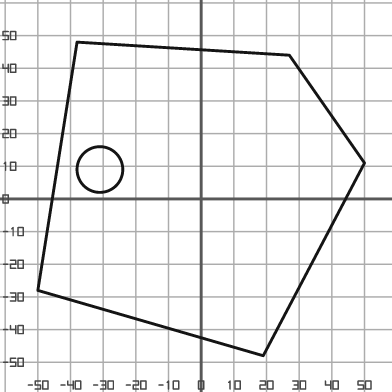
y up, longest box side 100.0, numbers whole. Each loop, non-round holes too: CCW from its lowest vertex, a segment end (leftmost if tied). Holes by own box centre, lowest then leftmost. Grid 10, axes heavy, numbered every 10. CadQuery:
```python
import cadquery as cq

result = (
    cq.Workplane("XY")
    .moveTo(19.0, -48.0)
    .lineTo(50.0, 11.0)
    .lineTo(27.0, 44.0)
    .lineTo(-38.0, 48.0)
    .lineTo(-50.0, -28.0)
    .close()
    .moveTo(-31.0, 9.0)
    .circle(7.0)
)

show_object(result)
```